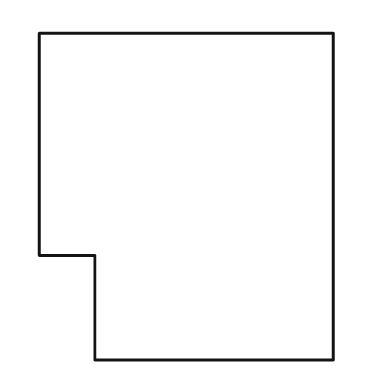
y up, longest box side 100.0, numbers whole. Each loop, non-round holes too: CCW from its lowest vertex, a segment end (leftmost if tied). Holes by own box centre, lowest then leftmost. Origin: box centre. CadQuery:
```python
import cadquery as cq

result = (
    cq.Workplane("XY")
    .moveTo(-28.0, -50.0)
    .lineTo(45.0, -50.0)
    .lineTo(45.0, 50.0)
    .lineTo(-45.0, 50.0)
    .lineTo(-45.0, -18.0)
    .lineTo(-28.0, -18.0)
    .close()
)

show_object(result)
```